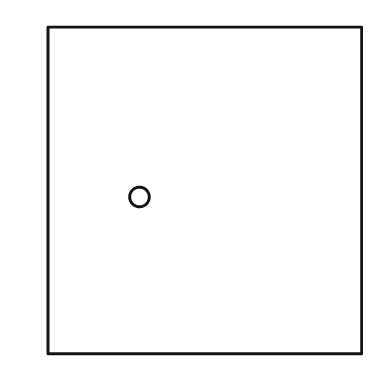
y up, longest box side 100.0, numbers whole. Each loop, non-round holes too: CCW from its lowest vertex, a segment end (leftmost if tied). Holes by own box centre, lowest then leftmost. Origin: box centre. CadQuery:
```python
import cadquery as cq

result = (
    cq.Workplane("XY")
    .moveTo(-48.0, -50.0)
    .lineTo(48.0, -50.0)
    .lineTo(48.0, 50.0)
    .lineTo(-48.0, 50.0)
    .close()
    .moveTo(-20.0, -2.0)
    .circle(3.0)
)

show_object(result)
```